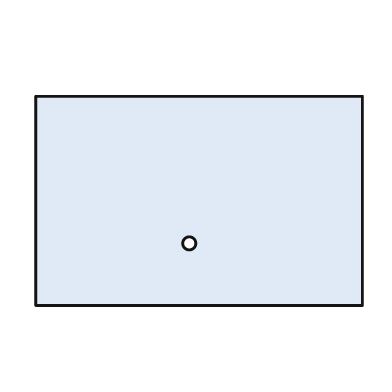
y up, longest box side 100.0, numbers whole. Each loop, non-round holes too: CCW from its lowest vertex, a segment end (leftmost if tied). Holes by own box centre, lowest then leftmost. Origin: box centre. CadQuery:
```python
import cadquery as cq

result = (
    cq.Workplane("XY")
    .moveTo(-50.0, -32.0)
    .lineTo(50.0, -32.0)
    .lineTo(50.0, 32.0)
    .lineTo(-50.0, 32.0)
    .close()
    .moveTo(-3.0, -13.0)
    .circle(2.0)
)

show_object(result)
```